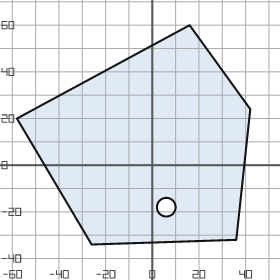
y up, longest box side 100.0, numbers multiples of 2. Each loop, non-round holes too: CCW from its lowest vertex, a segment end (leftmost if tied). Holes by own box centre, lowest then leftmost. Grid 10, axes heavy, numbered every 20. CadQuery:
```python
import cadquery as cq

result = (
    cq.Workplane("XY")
    .moveTo(-26.0, -34.0)
    .lineTo(36.0, -32.0)
    .lineTo(42.0, 24.0)
    .lineTo(16.0, 60.0)
    .lineTo(-58.0, 20.0)
    .close()
    .moveTo(6.0, -18.0)
    .circle(4.0)
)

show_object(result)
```